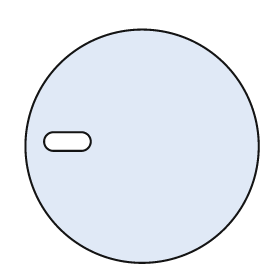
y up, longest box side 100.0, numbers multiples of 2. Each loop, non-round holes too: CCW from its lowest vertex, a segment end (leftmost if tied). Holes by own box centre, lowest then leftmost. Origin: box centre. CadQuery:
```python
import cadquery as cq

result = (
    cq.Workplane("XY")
    .moveTo(0.0, 0.0)
    .circle(50.0)
    .moveTo(-38.0, -2.0)
    .lineTo(-26.0, -2.0)
    .threePointArc((-22.0, 2.0), (-26.0, 6.0))
    .lineTo(-38.0, 6.0)
    .threePointArc((-42.0, 2.0), (-38.0, -2.0))
    .close()
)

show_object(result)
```